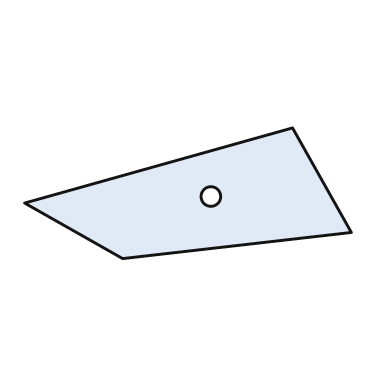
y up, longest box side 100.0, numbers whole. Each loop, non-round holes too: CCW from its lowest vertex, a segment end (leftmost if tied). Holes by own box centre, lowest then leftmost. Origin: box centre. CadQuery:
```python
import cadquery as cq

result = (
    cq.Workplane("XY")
    .moveTo(-20.0, -20.0)
    .lineTo(50.0, -12.0)
    .lineTo(32.0, 20.0)
    .lineTo(-50.0, -3.0)
    .close()
    .moveTo(7.0, -1.0)
    .circle(3.0)
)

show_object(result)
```